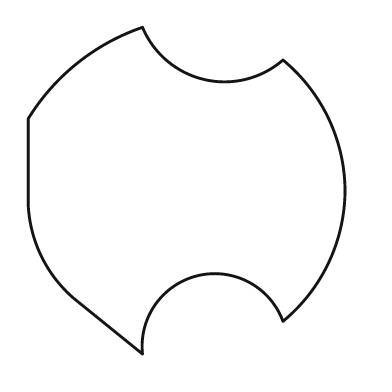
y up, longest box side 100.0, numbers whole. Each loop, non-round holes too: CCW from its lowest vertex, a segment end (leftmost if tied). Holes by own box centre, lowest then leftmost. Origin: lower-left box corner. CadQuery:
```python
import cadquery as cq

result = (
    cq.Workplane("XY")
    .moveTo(35.0, 0.0)
    .threePointArc((52.0, 24.0), (78.0, 10.0))
    .threePointArc((92.0, 28.0), (97.0, 50.0))
    .threePointArc((92.0, 72.0), (78.0, 90.0))
    .threePointArc((54.0, 84.0), (35.0, 100.0))
    .threePointArc((15.0, 89.0), (0.0, 72.0))
    .lineTo(0.0, 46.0)
    .threePointArc((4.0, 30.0), (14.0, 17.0))
    .close()
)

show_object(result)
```